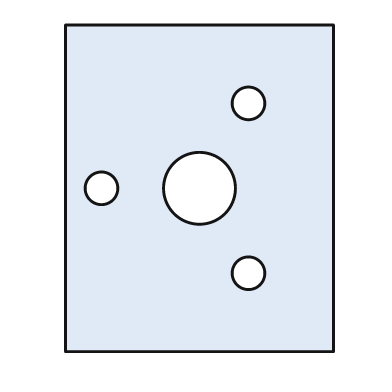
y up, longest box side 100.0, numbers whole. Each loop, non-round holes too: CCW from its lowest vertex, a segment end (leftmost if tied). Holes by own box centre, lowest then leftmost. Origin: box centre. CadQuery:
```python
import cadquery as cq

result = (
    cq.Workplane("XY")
    .moveTo(-41.0, -50.0)
    .lineTo(41.0, -50.0)
    .lineTo(41.0, 50.0)
    .lineTo(-41.0, 50.0)
    .close()
    .moveTo(15.0, -26.0)
    .circle(5.0)
    .moveTo(-30.0, 0.0)
    .circle(5.0)
    .moveTo(0.0, 0.0)
    .circle(11.0)
    .moveTo(15.0, 26.0)
    .circle(5.0)
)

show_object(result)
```